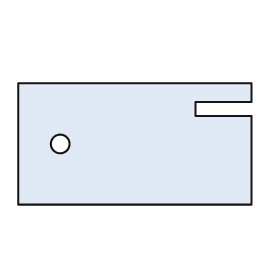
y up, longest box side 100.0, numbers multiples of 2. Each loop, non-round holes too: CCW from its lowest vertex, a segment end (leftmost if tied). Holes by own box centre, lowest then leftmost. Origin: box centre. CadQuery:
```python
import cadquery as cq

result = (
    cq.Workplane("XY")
    .moveTo(-50.0, -26.0)
    .lineTo(50.0, -26.0)
    .lineTo(50.0, 12.0)
    .lineTo(26.0, 12.0)
    .lineTo(26.0, 18.0)
    .lineTo(50.0, 18.0)
    .lineTo(50.0, 26.0)
    .lineTo(-50.0, 26.0)
    .close()
    .moveTo(-32.0, 0.0)
    .circle(4.0)
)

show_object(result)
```